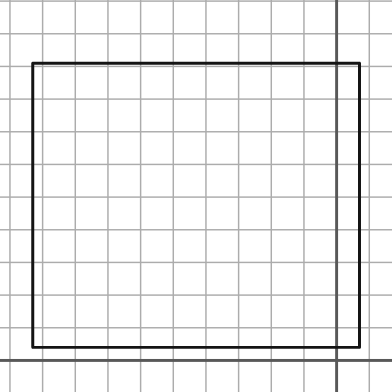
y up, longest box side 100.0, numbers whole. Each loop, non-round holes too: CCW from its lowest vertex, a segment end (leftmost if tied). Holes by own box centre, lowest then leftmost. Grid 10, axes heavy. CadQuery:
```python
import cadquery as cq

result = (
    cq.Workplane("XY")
    .moveTo(-93.0, 4.0)
    .lineTo(7.0, 4.0)
    .lineTo(7.0, 91.0)
    .lineTo(-93.0, 91.0)
    .close()
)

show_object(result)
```